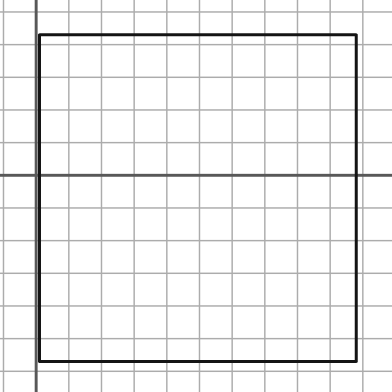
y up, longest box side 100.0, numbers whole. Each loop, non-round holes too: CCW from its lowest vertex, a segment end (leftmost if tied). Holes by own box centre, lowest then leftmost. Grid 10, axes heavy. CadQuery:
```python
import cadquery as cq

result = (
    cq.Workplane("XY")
    .moveTo(1.0, -57.0)
    .lineTo(98.0, -57.0)
    .lineTo(98.0, 43.0)
    .lineTo(1.0, 43.0)
    .close()
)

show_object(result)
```